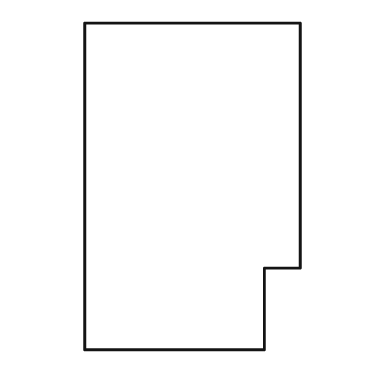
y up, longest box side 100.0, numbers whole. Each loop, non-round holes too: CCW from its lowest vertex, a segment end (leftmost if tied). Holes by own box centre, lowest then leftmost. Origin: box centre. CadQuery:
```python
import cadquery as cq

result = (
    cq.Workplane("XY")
    .moveTo(-33.0, -50.0)
    .lineTo(22.0, -50.0)
    .lineTo(22.0, -25.0)
    .lineTo(33.0, -25.0)
    .lineTo(33.0, 50.0)
    .lineTo(-33.0, 50.0)
    .close()
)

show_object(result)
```